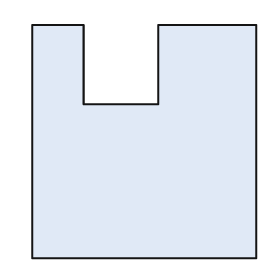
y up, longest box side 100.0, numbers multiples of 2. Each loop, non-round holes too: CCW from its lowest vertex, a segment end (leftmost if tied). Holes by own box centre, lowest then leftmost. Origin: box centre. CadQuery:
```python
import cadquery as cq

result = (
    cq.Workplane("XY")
    .moveTo(-48.0, -50.0)
    .lineTo(48.0, -50.0)
    .lineTo(48.0, 50.0)
    .lineTo(6.0, 50.0)
    .lineTo(6.0, 16.0)
    .lineTo(-26.0, 16.0)
    .lineTo(-26.0, 50.0)
    .lineTo(-48.0, 50.0)
    .close()
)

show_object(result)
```